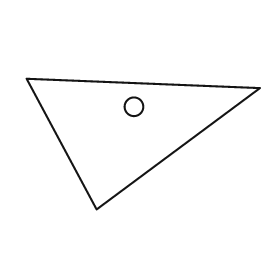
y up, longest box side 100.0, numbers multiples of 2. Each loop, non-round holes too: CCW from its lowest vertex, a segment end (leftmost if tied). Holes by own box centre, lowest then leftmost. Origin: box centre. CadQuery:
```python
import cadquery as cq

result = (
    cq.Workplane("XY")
    .moveTo(-20.0, -28.0)
    .lineTo(50.0, 24.0)
    .lineTo(-50.0, 28.0)
    .close()
    .moveTo(-4.0, 16.0)
    .circle(4.0)
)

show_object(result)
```